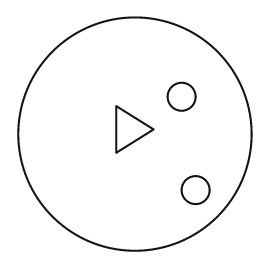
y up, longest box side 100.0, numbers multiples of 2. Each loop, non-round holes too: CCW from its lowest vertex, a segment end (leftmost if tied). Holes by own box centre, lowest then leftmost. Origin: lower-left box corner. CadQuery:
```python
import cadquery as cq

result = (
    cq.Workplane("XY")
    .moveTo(50.0, 50.0)
    .circle(50.0)
    .moveTo(76.0, 26.0)
    .circle(6.0)
    .moveTo(42.0, 42.0)
    .lineTo(58.0, 52.0)
    .lineTo(42.0, 62.0)
    .close()
    .moveTo(70.0, 66.0)
    .circle(6.0)
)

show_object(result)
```